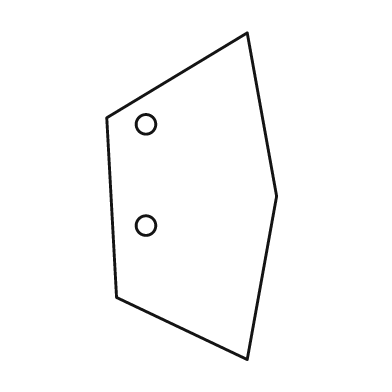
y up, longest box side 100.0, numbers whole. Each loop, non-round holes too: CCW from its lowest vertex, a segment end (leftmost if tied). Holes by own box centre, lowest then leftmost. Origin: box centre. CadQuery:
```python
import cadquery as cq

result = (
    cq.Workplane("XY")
    .moveTo(17.0, -50.0)
    .lineTo(26.0, 0.0)
    .lineTo(17.0, 50.0)
    .lineTo(-26.0, 24.0)
    .lineTo(-23.0, -31.0)
    .close()
    .moveTo(-14.0, -9.0)
    .circle(3.0)
    .moveTo(-14.0, 22.0)
    .circle(3.0)
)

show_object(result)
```